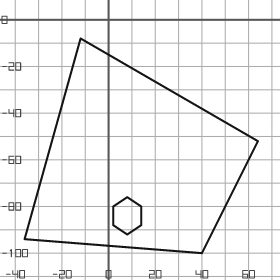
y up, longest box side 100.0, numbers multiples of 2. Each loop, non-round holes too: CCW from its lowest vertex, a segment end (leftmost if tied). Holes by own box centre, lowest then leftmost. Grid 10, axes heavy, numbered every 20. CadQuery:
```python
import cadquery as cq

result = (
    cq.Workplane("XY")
    .moveTo(40.0, -100.0)
    .lineTo(64.0, -52.0)
    .lineTo(-12.0, -8.0)
    .lineTo(-36.0, -94.0)
    .close()
    .moveTo(8.0, -92.0)
    .lineTo(14.0, -88.0)
    .lineTo(14.0, -80.0)
    .lineTo(8.0, -76.0)
    .lineTo(2.0, -80.0)
    .lineTo(2.0, -88.0)
    .close()
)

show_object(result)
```